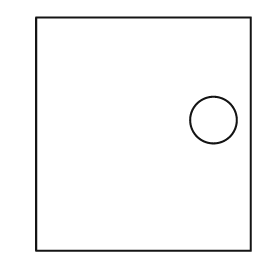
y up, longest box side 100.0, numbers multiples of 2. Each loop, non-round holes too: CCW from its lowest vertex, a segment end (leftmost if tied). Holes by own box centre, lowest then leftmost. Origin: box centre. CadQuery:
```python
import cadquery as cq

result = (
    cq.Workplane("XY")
    .moveTo(-46.0, -50.0)
    .lineTo(46.0, -50.0)
    .lineTo(46.0, 50.0)
    .lineTo(-46.0, 50.0)
    .close()
    .moveTo(30.0, 6.0)
    .circle(10.0)
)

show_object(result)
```